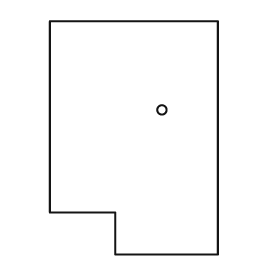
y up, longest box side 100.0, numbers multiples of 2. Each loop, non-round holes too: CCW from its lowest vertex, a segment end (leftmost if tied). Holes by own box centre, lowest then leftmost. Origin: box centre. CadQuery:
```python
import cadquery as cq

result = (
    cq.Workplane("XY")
    .moveTo(-8.0, -50.0)
    .lineTo(36.0, -50.0)
    .lineTo(36.0, 50.0)
    .lineTo(-36.0, 50.0)
    .lineTo(-36.0, -32.0)
    .lineTo(-8.0, -32.0)
    .close()
    .moveTo(12.0, 12.0)
    .circle(2.0)
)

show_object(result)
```